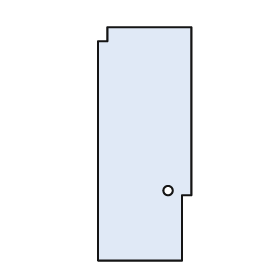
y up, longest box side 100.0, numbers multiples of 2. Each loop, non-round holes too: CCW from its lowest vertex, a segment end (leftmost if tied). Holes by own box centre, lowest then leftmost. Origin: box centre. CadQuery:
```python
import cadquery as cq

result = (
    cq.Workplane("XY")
    .moveTo(-20.0, -50.0)
    .lineTo(16.0, -50.0)
    .lineTo(16.0, -22.0)
    .lineTo(20.0, -22.0)
    .lineTo(20.0, 50.0)
    .lineTo(-16.0, 50.0)
    .lineTo(-16.0, 44.0)
    .lineTo(-20.0, 44.0)
    .close()
    .moveTo(10.0, -20.0)
    .circle(2.0)
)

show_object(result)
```